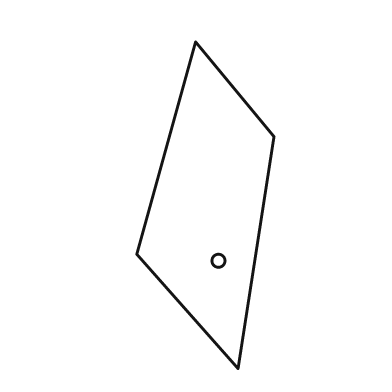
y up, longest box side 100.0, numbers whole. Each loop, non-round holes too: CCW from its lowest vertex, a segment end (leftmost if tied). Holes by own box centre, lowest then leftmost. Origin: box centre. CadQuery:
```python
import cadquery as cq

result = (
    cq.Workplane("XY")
    .moveTo(10.0, -50.0)
    .lineTo(21.0, 21.0)
    .lineTo(-3.0, 50.0)
    .lineTo(-21.0, -15.0)
    .close()
    .moveTo(4.0, -17.0)
    .circle(2.0)
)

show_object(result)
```